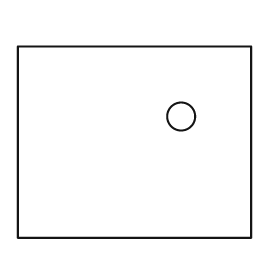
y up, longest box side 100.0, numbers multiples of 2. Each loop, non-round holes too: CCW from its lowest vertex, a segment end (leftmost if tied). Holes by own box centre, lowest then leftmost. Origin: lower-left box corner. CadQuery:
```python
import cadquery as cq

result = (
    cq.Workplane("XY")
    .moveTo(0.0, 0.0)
    .lineTo(100.0, 0.0)
    .lineTo(100.0, 82.0)
    .lineTo(0.0, 82.0)
    .close()
    .moveTo(70.0, 52.0)
    .circle(6.0)
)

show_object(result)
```